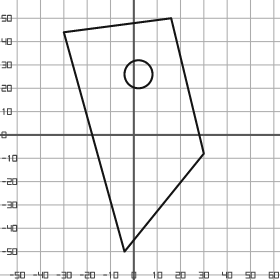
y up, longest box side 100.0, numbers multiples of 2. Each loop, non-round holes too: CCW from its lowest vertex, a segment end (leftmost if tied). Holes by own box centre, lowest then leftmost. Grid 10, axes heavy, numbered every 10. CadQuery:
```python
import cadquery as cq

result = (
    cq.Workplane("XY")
    .moveTo(-4.0, -50.0)
    .lineTo(30.0, -8.0)
    .lineTo(16.0, 50.0)
    .lineTo(-30.0, 44.0)
    .close()
    .moveTo(2.0, 26.0)
    .circle(6.0)
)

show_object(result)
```